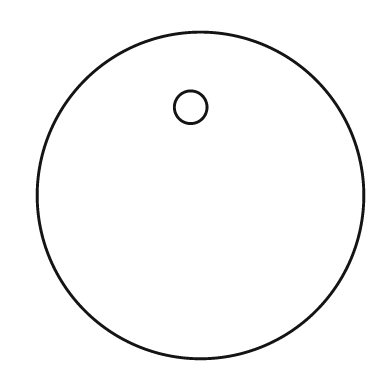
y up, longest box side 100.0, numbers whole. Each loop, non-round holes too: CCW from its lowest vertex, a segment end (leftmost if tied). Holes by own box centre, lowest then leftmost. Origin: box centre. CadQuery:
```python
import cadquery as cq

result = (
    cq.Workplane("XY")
    .moveTo(0.0, 0.0)
    .circle(50.0)
    .moveTo(-3.0, 27.0)
    .circle(5.0)
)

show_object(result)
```